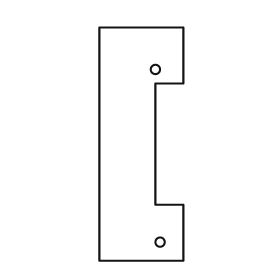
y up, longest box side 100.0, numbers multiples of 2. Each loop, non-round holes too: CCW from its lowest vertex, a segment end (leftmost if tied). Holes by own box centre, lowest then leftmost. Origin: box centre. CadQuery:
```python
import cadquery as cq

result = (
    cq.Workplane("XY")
    .moveTo(-18.0, -50.0)
    .lineTo(18.0, -50.0)
    .lineTo(18.0, -26.0)
    .lineTo(6.0, -26.0)
    .lineTo(6.0, 26.0)
    .lineTo(18.0, 26.0)
    .lineTo(18.0, 50.0)
    .lineTo(-18.0, 50.0)
    .close()
    .moveTo(8.0, -42.0)
    .circle(2.0)
    .moveTo(6.0, 32.0)
    .circle(2.0)
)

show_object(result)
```